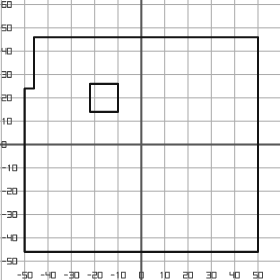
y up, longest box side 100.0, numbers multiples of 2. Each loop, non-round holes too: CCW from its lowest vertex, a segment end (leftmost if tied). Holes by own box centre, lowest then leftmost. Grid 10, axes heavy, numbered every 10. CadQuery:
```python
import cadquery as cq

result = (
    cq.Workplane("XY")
    .moveTo(-50.0, -46.0)
    .lineTo(50.0, -46.0)
    .lineTo(50.0, 46.0)
    .lineTo(-46.0, 46.0)
    .lineTo(-46.0, 24.0)
    .lineTo(-50.0, 24.0)
    .close()
    .moveTo(-22.0, 14.0)
    .lineTo(-10.0, 14.0)
    .lineTo(-10.0, 26.0)
    .lineTo(-22.0, 26.0)
    .close()
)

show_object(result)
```